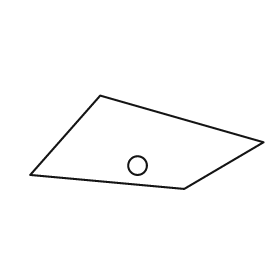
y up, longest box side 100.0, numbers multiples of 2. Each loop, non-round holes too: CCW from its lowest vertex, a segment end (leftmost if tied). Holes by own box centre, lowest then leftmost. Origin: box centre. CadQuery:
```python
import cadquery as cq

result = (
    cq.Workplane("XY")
    .moveTo(16.0, -20.0)
    .lineTo(50.0, 0.0)
    .lineTo(-20.0, 20.0)
    .lineTo(-50.0, -14.0)
    .close()
    .moveTo(-4.0, -10.0)
    .circle(4.0)
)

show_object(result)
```